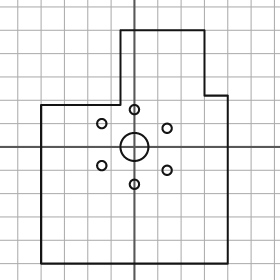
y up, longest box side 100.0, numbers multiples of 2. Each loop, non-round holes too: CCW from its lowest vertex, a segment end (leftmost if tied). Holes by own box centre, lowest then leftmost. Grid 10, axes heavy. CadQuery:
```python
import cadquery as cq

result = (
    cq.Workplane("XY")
    .moveTo(-40.0, -50.0)
    .lineTo(40.0, -50.0)
    .lineTo(40.0, 22.0)
    .lineTo(30.0, 22.0)
    .lineTo(30.0, 50.0)
    .lineTo(-6.0, 50.0)
    .lineTo(-6.0, 18.0)
    .lineTo(-40.0, 18.0)
    .close()
    .moveTo(0.0, -16.0)
    .circle(2.0)
    .moveTo(14.0, -10.0)
    .circle(2.0)
    .moveTo(-14.0, -8.0)
    .circle(2.0)
    .moveTo(0.0, 0.0)
    .circle(6.0)
    .moveTo(14.0, 8.0)
    .circle(2.0)
    .moveTo(-14.0, 10.0)
    .circle(2.0)
    .moveTo(0.0, 16.0)
    .circle(2.0)
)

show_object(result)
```